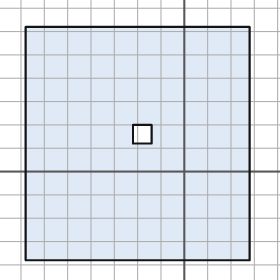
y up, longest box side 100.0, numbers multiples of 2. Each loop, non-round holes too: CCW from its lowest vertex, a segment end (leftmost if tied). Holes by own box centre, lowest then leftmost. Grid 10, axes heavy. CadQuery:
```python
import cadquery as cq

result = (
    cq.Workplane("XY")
    .moveTo(-68.0, -38.0)
    .lineTo(28.0, -38.0)
    .lineTo(28.0, 62.0)
    .lineTo(-68.0, 62.0)
    .close()
    .moveTo(-22.0, 12.0)
    .lineTo(-14.0, 12.0)
    .lineTo(-14.0, 20.0)
    .lineTo(-22.0, 20.0)
    .close()
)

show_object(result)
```